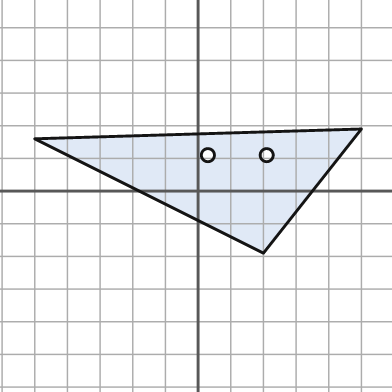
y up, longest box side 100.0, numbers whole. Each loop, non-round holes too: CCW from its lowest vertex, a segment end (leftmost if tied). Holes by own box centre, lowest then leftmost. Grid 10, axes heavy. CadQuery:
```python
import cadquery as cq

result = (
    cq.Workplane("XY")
    .moveTo(20.0, -19.0)
    .lineTo(50.0, 19.0)
    .lineTo(-50.0, 16.0)
    .close()
    .moveTo(3.0, 11.0)
    .circle(2.0)
    .moveTo(21.0, 11.0)
    .circle(2.0)
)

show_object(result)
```